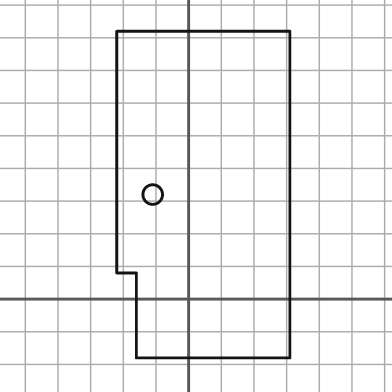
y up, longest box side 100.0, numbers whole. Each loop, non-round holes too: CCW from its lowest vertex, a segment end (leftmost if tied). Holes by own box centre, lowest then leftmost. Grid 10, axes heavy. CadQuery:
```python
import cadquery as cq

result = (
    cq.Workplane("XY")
    .moveTo(-16.0, -18.0)
    .lineTo(31.0, -18.0)
    .lineTo(31.0, 82.0)
    .lineTo(-22.0, 82.0)
    .lineTo(-22.0, 8.0)
    .lineTo(-16.0, 8.0)
    .close()
    .moveTo(-11.0, 32.0)
    .circle(3.0)
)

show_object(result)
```